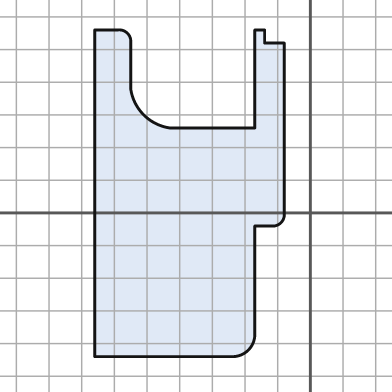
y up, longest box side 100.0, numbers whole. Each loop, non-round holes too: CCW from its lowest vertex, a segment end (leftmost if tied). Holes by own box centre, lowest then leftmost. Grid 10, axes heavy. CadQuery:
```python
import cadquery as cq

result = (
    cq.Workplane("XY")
    .moveTo(-66.0, -44.0)
    .lineTo(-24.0, -44.0)
    .threePointArc((-19.0, -42.0), (-17.0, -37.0))
    .lineTo(-17.0, -4.0)
    .lineTo(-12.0, -4.0)
    .threePointArc((-9.0, -3.0), (-8.0, 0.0))
    .lineTo(-8.0, 52.0)
    .lineTo(-14.0, 52.0)
    .lineTo(-14.0, 56.0)
    .lineTo(-17.0, 56.0)
    .lineTo(-17.0, 26.0)
    .lineTo(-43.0, 26.0)
    .threePointArc((-51.0, 30.0), (-55.0, 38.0))
    .lineTo(-55.0, 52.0)
    .threePointArc((-56.0, 55.0), (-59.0, 56.0))
    .lineTo(-66.0, 56.0)
    .close()
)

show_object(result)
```